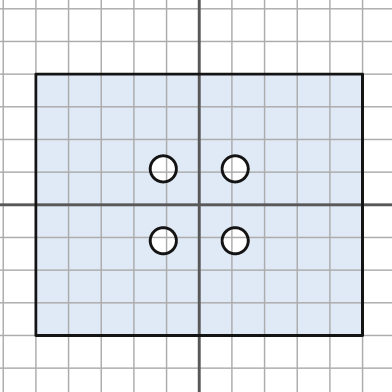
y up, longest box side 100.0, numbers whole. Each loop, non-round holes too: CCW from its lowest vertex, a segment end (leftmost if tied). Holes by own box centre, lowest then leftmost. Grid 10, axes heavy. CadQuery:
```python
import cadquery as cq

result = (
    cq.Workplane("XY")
    .moveTo(-50.0, -40.0)
    .lineTo(50.0, -40.0)
    .lineTo(50.0, 40.0)
    .lineTo(-50.0, 40.0)
    .close()
    .moveTo(-11.0, -11.0)
    .circle(4.0)
    .moveTo(11.0, -11.0)
    .circle(4.0)
    .moveTo(-11.0, 11.0)
    .circle(4.0)
    .moveTo(11.0, 11.0)
    .circle(4.0)
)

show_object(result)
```